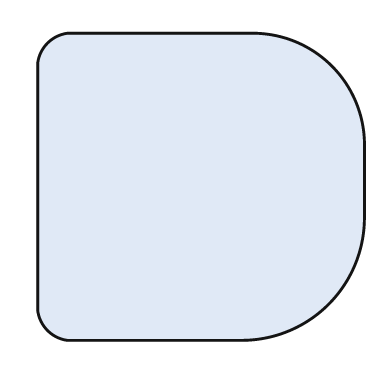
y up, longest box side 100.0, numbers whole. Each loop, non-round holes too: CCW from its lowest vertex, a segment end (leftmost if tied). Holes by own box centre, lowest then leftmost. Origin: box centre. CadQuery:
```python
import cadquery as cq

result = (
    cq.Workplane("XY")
    .moveTo(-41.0, -47.0)
    .lineTo(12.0, -47.0)
    .threePointArc((39.0, -36.0), (50.0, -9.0))
    .lineTo(50.0, 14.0)
    .threePointArc((40.0, 37.0), (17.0, 47.0))
    .lineTo(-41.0, 47.0)
    .threePointArc((-47.0, 44.0), (-50.0, 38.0))
    .lineTo(-50.0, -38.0)
    .threePointArc((-47.0, -44.0), (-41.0, -47.0))
    .close()
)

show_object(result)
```